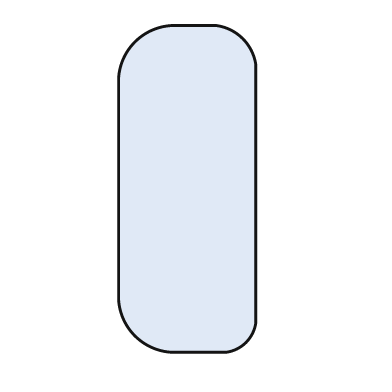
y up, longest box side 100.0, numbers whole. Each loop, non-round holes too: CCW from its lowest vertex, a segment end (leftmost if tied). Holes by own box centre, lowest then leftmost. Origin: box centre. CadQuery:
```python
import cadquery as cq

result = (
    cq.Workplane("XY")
    .moveTo(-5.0, -50.0)
    .lineTo(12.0, -50.0)
    .threePointArc((18.0, -47.0), (21.0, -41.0))
    .lineTo(21.0, 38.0)
    .threePointArc((17.0, 46.0), (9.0, 50.0))
    .lineTo(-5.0, 50.0)
    .threePointArc((-16.0, 45.0), (-21.0, 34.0))
    .lineTo(-21.0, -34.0)
    .threePointArc((-16.0, -45.0), (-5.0, -50.0))
    .close()
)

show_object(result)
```